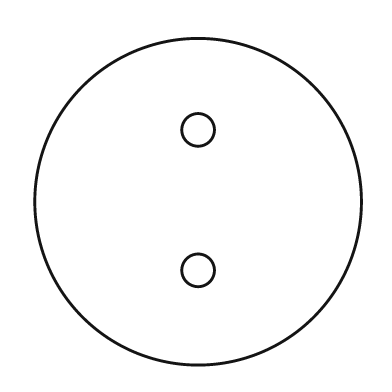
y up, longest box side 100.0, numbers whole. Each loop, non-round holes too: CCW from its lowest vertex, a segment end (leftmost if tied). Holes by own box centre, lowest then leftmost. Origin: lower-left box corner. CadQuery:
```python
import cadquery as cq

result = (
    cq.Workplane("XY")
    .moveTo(50.0, 50.0)
    .circle(50.0)
    .moveTo(50.0, 29.0)
    .circle(5.0)
    .moveTo(50.0, 72.0)
    .circle(5.0)
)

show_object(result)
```